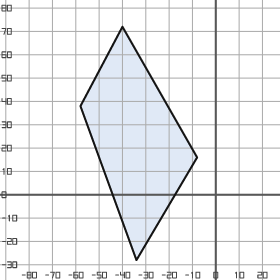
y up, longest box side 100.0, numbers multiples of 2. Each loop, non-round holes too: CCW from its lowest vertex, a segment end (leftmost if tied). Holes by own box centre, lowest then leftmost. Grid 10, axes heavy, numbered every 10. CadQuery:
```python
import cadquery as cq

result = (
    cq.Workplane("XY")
    .moveTo(-34.0, -28.0)
    .lineTo(-8.0, 16.0)
    .lineTo(-40.0, 72.0)
    .lineTo(-58.0, 38.0)
    .close()
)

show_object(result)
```